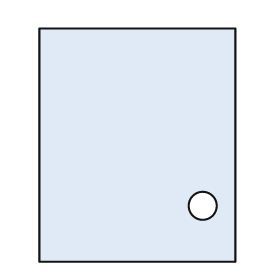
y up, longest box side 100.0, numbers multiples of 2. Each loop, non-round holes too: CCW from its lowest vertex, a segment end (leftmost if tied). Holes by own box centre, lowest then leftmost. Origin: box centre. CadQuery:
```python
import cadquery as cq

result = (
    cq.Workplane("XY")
    .moveTo(-42.0, -50.0)
    .lineTo(42.0, -50.0)
    .lineTo(42.0, 50.0)
    .lineTo(-42.0, 50.0)
    .close()
    .moveTo(28.0, -26.0)
    .circle(6.0)
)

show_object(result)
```